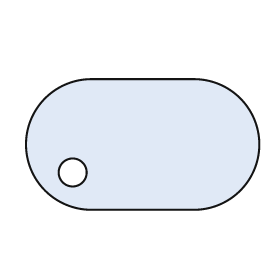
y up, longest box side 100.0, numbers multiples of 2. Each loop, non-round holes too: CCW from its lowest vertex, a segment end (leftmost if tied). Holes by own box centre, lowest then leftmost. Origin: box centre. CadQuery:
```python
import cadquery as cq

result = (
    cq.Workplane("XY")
    .moveTo(-22.0, -28.0)
    .lineTo(22.0, -28.0)
    .threePointArc((50.0, 0.0), (22.0, 28.0))
    .lineTo(-22.0, 28.0)
    .threePointArc((-50.0, 0.0), (-22.0, -28.0))
    .close()
    .moveTo(-30.0, -12.0)
    .circle(6.0)
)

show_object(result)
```